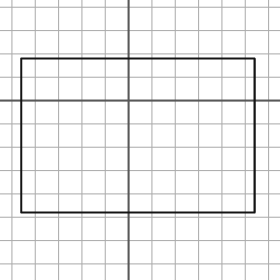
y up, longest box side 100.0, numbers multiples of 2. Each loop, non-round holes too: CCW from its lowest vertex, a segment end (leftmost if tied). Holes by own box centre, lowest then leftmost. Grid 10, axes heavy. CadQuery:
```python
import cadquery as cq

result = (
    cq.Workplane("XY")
    .moveTo(-46.0, -48.0)
    .lineTo(54.0, -48.0)
    .lineTo(54.0, 18.0)
    .lineTo(-46.0, 18.0)
    .close()
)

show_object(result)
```